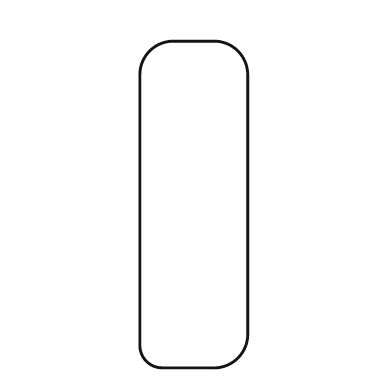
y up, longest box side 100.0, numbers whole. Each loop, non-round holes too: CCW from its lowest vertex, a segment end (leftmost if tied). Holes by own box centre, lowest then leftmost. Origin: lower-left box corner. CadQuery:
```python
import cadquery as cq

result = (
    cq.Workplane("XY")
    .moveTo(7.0, 0.0)
    .lineTo(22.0, 0.0)
    .threePointArc((30.0, 3.0), (33.0, 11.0))
    .lineTo(33.0, 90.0)
    .threePointArc((30.0, 97.0), (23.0, 100.0))
    .lineTo(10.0, 100.0)
    .threePointArc((3.0, 97.0), (0.0, 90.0))
    .lineTo(0.0, 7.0)
    .threePointArc((2.0, 2.0), (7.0, 0.0))
    .close()
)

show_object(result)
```